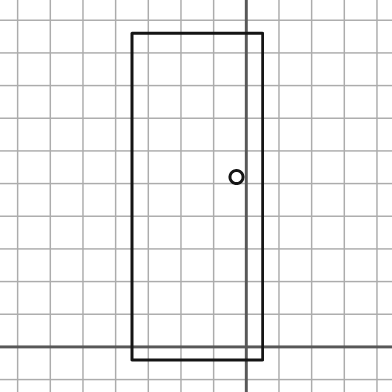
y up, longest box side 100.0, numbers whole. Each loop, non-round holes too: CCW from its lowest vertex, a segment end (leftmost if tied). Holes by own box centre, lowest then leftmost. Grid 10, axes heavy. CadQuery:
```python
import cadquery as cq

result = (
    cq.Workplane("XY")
    .moveTo(-35.0, -4.0)
    .lineTo(5.0, -4.0)
    .lineTo(5.0, 96.0)
    .lineTo(-35.0, 96.0)
    .close()
    .moveTo(-3.0, 52.0)
    .circle(2.0)
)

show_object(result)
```